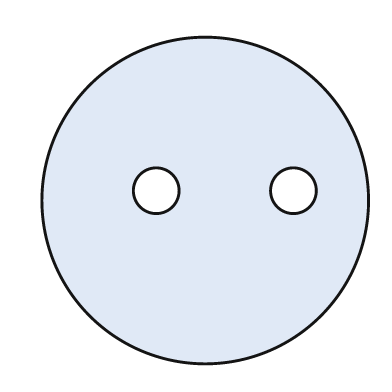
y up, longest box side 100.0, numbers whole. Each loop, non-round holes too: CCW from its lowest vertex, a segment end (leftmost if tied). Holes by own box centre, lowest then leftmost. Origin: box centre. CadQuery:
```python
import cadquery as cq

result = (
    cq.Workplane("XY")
    .moveTo(0.0, 0.0)
    .circle(50.0)
    .moveTo(-15.0, 3.0)
    .circle(7.0)
    .moveTo(27.0, 3.0)
    .circle(7.0)
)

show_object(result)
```